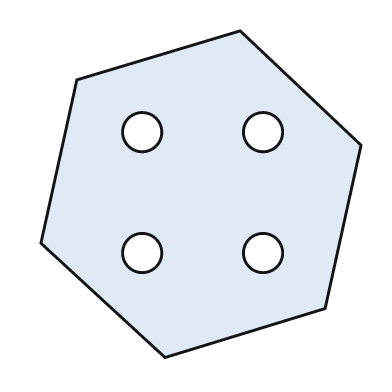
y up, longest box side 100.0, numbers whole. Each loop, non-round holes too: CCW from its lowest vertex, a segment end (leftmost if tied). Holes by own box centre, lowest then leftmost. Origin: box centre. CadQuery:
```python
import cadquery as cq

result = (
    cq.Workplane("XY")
    .moveTo(-11.0, -50.0)
    .lineTo(38.0, -35.0)
    .lineTo(49.0, 15.0)
    .lineTo(12.0, 50.0)
    .lineTo(-38.0, 35.0)
    .lineTo(-49.0, -15.0)
    .close()
    .moveTo(-18.0, -18.0)
    .circle(6.0)
    .moveTo(19.0, -18.0)
    .circle(6.0)
    .moveTo(-18.0, 19.0)
    .circle(6.0)
    .moveTo(19.0, 19.0)
    .circle(6.0)
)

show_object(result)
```